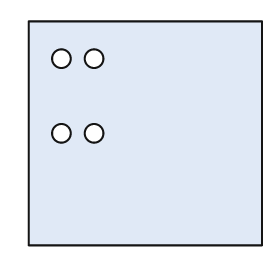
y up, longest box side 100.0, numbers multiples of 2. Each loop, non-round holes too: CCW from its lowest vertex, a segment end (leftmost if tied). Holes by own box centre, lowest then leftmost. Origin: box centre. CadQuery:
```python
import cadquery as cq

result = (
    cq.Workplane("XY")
    .moveTo(-50.0, -48.0)
    .lineTo(50.0, -48.0)
    .lineTo(50.0, 48.0)
    .lineTo(-50.0, 48.0)
    .close()
    .moveTo(-36.0, 0.0)
    .circle(4.0)
    .moveTo(-22.0, 0.0)
    .circle(4.0)
    .moveTo(-36.0, 32.0)
    .circle(4.0)
    .moveTo(-22.0, 32.0)
    .circle(4.0)
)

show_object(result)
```